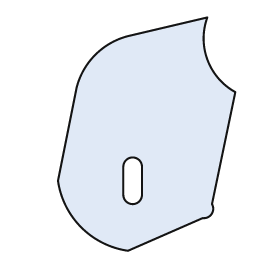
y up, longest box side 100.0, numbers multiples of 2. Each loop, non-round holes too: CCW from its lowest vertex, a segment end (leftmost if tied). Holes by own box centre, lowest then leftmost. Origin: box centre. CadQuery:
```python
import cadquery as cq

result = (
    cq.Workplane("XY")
    .moveTo(-8.0, -50.0)
    .lineTo(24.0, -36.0)
    .threePointArc((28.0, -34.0), (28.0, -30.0))
    .lineTo(38.0, 18.0)
    .threePointArc((26.0, 32.0), (26.0, 50.0))
    .lineTo(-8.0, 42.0)
    .threePointArc((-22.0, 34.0), (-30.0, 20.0))
    .lineTo(-38.0, -20.0)
    .threePointArc((-28.0, -40.0), (-8.0, -50.0))
    .close()
    .moveTo(-10.0, -26.0)
    .threePointArc((-6.0, -30.0), (-2.0, -26.0))
    .lineTo(-2.0, -14.0)
    .threePointArc((-6.0, -10.0), (-10.0, -14.0))
    .close()
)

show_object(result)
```